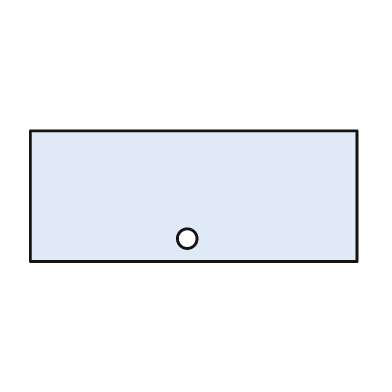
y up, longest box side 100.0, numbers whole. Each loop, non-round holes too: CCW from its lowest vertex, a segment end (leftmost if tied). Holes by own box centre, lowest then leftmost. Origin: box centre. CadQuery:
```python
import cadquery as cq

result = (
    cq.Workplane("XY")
    .moveTo(-50.0, -20.0)
    .lineTo(50.0, -20.0)
    .lineTo(50.0, 20.0)
    .lineTo(-50.0, 20.0)
    .close()
    .moveTo(-2.0, -13.0)
    .circle(3.0)
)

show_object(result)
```